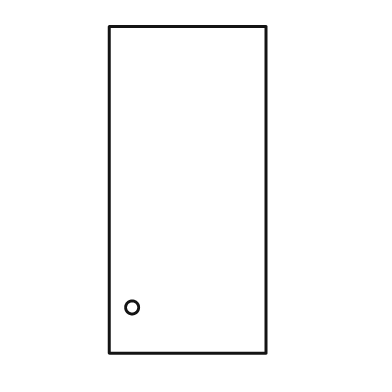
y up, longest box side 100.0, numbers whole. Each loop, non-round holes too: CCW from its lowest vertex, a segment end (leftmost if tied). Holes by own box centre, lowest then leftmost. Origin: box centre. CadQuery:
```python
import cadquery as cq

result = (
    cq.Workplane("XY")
    .moveTo(-24.0, -50.0)
    .lineTo(24.0, -50.0)
    .lineTo(24.0, 50.0)
    .lineTo(-24.0, 50.0)
    .close()
    .moveTo(-17.0, -36.0)
    .circle(2.0)
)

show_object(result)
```